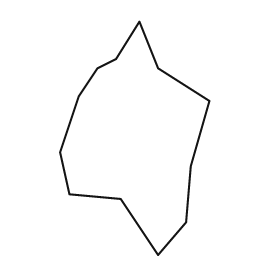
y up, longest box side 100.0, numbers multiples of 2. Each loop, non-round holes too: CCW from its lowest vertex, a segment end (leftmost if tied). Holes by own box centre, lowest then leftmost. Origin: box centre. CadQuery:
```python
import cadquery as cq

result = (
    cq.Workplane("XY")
    .moveTo(10.0, -50.0)
    .lineTo(22.0, -36.0)
    .lineTo(24.0, -12.0)
    .lineTo(32.0, 16.0)
    .lineTo(10.0, 30.0)
    .lineTo(2.0, 50.0)
    .lineTo(-8.0, 34.0)
    .lineTo(-16.0, 30.0)
    .lineTo(-24.0, 18.0)
    .lineTo(-32.0, -6.0)
    .lineTo(-28.0, -24.0)
    .lineTo(-6.0, -26.0)
    .close()
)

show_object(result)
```